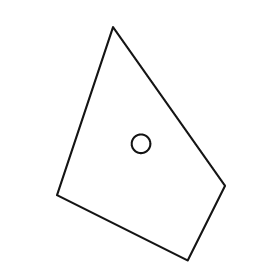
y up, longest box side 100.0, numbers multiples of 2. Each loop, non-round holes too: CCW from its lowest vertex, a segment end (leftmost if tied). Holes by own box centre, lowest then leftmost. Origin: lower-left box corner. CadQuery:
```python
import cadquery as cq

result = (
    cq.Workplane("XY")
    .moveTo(56.0, 0.0)
    .lineTo(72.0, 32.0)
    .lineTo(24.0, 100.0)
    .lineTo(0.0, 28.0)
    .close()
    .moveTo(36.0, 50.0)
    .circle(4.0)
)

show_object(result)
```